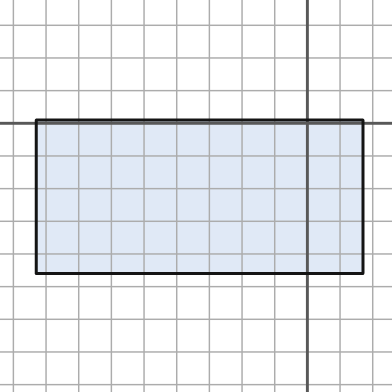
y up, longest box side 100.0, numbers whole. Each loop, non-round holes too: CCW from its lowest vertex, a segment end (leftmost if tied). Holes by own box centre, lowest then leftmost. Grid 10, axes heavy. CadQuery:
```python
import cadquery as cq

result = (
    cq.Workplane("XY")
    .moveTo(-83.0, -46.0)
    .lineTo(17.0, -46.0)
    .lineTo(17.0, 1.0)
    .lineTo(-83.0, 1.0)
    .close()
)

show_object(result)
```